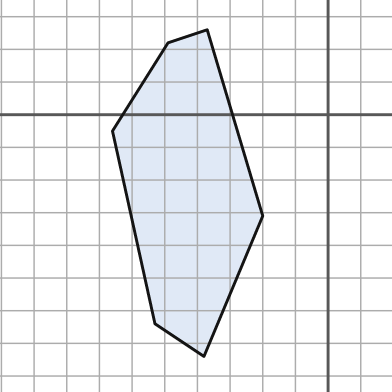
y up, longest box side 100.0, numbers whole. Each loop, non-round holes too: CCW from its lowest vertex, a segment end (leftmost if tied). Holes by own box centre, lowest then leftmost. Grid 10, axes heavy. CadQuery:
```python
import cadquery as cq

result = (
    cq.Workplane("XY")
    .moveTo(-38.0, -74.0)
    .lineTo(-20.0, -31.0)
    .lineTo(-37.0, 26.0)
    .lineTo(-49.0, 22.0)
    .lineTo(-66.0, -5.0)
    .lineTo(-53.0, -64.0)
    .close()
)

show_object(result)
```